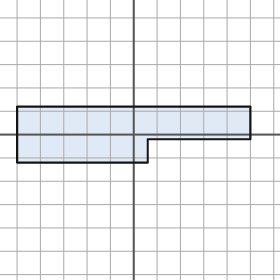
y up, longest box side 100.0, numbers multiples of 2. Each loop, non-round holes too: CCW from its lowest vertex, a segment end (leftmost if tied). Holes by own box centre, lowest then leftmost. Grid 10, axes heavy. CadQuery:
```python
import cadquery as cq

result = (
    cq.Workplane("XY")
    .moveTo(-50.0, -12.0)
    .lineTo(6.0, -12.0)
    .lineTo(6.0, -2.0)
    .lineTo(50.0, -2.0)
    .lineTo(50.0, 12.0)
    .lineTo(-50.0, 12.0)
    .close()
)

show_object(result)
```